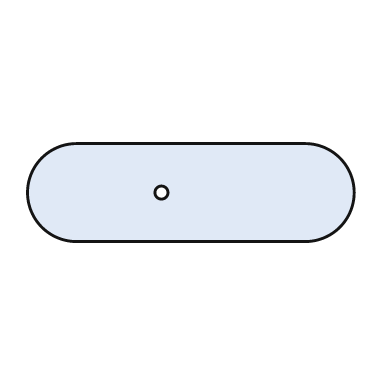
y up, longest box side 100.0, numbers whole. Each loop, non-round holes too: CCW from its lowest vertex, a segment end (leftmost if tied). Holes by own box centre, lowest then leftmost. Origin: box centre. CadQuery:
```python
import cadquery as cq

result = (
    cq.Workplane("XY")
    .moveTo(-35.0, -15.0)
    .lineTo(35.0, -15.0)
    .threePointArc((50.0, 0.0), (35.0, 15.0))
    .lineTo(-35.0, 15.0)
    .threePointArc((-50.0, 0.0), (-35.0, -15.0))
    .close()
    .moveTo(-9.0, 0.0)
    .circle(2.0)
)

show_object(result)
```